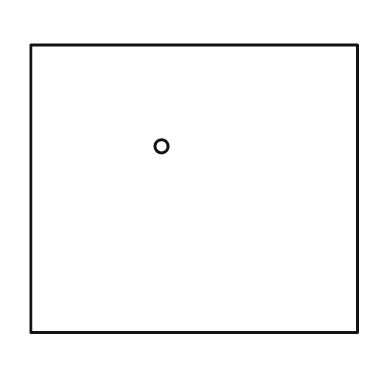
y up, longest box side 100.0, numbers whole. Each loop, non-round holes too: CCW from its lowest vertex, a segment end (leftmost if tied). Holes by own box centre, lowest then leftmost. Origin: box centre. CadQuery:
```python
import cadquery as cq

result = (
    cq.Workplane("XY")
    .moveTo(-50.0, -44.0)
    .lineTo(50.0, -44.0)
    .lineTo(50.0, 44.0)
    .lineTo(-50.0, 44.0)
    .close()
    .moveTo(-10.0, 13.0)
    .circle(2.0)
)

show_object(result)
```